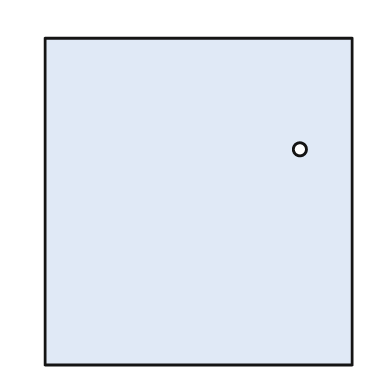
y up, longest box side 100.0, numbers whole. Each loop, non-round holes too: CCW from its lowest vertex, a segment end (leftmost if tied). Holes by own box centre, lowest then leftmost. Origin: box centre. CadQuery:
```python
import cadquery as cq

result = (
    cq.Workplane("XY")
    .moveTo(-47.0, -50.0)
    .lineTo(47.0, -50.0)
    .lineTo(47.0, 50.0)
    .lineTo(-47.0, 50.0)
    .close()
    .moveTo(31.0, 16.0)
    .circle(2.0)
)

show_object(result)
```